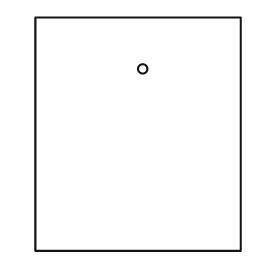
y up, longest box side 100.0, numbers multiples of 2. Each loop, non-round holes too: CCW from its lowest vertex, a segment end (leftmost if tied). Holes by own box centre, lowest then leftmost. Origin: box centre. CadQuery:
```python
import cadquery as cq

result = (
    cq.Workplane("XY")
    .moveTo(-44.0, -50.0)
    .lineTo(44.0, -50.0)
    .lineTo(44.0, 50.0)
    .lineTo(-44.0, 50.0)
    .close()
    .moveTo(2.0, 28.0)
    .circle(2.0)
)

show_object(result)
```